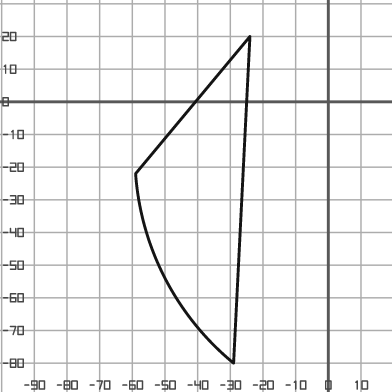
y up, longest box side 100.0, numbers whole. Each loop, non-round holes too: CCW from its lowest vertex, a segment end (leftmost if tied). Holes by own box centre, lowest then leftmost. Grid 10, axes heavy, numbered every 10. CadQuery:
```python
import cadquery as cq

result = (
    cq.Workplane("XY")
    .moveTo(-29.0, -80.0)
    .lineTo(-24.0, 20.0)
    .lineTo(-59.0, -22.0)
    .threePointArc((-50.0, -54.0), (-29.0, -80.0))
    .close()
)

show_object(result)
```